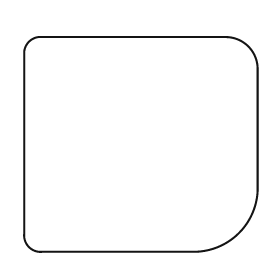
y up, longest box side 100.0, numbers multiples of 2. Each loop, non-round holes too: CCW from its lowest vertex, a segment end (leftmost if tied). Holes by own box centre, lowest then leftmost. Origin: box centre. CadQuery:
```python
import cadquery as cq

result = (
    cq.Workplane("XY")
    .moveTo(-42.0, -46.0)
    .lineTo(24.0, -46.0)
    .threePointArc((42.0, -38.0), (50.0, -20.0))
    .lineTo(50.0, 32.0)
    .threePointArc((46.0, 42.0), (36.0, 46.0))
    .lineTo(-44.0, 46.0)
    .threePointArc((-48.0, 44.0), (-50.0, 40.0))
    .lineTo(-50.0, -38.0)
    .threePointArc((-48.0, -44.0), (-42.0, -46.0))
    .close()
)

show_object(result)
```